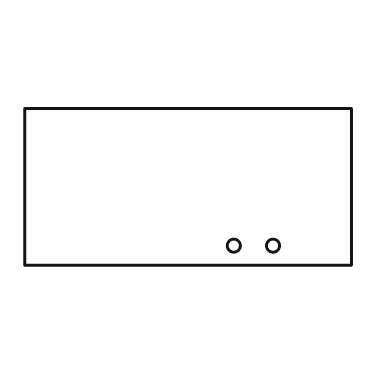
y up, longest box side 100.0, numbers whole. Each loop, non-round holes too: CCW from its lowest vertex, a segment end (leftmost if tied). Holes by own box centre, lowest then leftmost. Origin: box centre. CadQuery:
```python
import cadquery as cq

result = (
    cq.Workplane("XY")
    .moveTo(-50.0, -24.0)
    .lineTo(50.0, -24.0)
    .lineTo(50.0, 24.0)
    .lineTo(-50.0, 24.0)
    .close()
    .moveTo(14.0, -18.0)
    .circle(2.0)
    .moveTo(26.0, -18.0)
    .circle(2.0)
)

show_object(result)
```